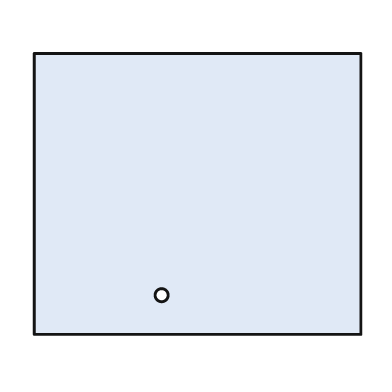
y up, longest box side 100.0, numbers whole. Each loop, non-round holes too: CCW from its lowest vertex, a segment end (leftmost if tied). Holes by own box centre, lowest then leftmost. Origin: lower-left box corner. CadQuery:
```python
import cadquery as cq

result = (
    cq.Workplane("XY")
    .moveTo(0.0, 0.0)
    .lineTo(100.0, 0.0)
    .lineTo(100.0, 86.0)
    .lineTo(0.0, 86.0)
    .close()
    .moveTo(39.0, 12.0)
    .circle(2.0)
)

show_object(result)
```